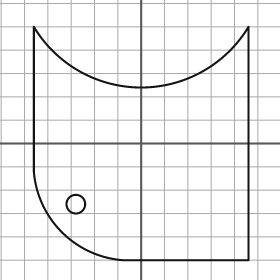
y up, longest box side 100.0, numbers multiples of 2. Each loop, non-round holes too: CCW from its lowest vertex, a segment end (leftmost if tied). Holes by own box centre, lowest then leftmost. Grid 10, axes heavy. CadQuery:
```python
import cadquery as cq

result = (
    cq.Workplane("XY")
    .moveTo(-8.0, -50.0)
    .lineTo(46.0, -50.0)
    .lineTo(46.0, 50.0)
    .threePointArc((0.0, 24.0), (-46.0, 50.0))
    .lineTo(-46.0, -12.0)
    .threePointArc((-34.0, -38.0), (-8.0, -50.0))
    .close()
    .moveTo(-28.0, -26.0)
    .circle(4.0)
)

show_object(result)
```